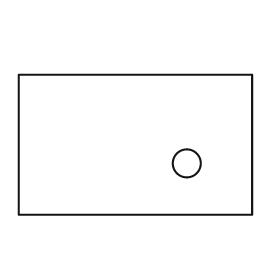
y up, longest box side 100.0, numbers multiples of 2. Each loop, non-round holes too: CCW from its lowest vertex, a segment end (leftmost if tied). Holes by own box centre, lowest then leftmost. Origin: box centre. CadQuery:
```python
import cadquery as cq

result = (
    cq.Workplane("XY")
    .moveTo(-50.0, -30.0)
    .lineTo(50.0, -30.0)
    .lineTo(50.0, 30.0)
    .lineTo(-50.0, 30.0)
    .close()
    .moveTo(22.0, -8.0)
    .circle(6.0)
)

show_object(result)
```